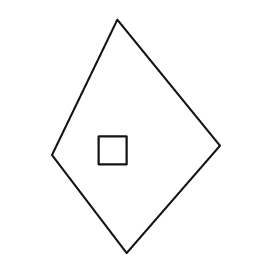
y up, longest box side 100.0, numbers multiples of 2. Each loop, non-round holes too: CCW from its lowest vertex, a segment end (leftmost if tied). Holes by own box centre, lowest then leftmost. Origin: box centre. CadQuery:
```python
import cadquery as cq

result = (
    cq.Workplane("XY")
    .moveTo(-4.0, -50.0)
    .lineTo(36.0, -4.0)
    .lineTo(-8.0, 50.0)
    .lineTo(-36.0, -8.0)
    .close()
    .moveTo(-16.0, -12.0)
    .lineTo(-4.0, -12.0)
    .lineTo(-4.0, 0.0)
    .lineTo(-16.0, 0.0)
    .close()
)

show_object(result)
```